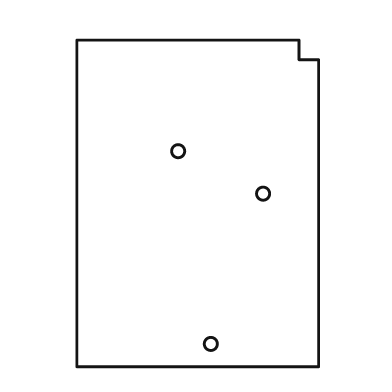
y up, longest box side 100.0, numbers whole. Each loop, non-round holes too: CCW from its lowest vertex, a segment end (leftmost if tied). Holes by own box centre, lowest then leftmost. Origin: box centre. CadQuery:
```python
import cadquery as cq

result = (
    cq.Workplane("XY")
    .moveTo(-37.0, -50.0)
    .lineTo(37.0, -50.0)
    .lineTo(37.0, 44.0)
    .lineTo(31.0, 44.0)
    .lineTo(31.0, 50.0)
    .lineTo(-37.0, 50.0)
    .close()
    .moveTo(4.0, -43.0)
    .circle(2.0)
    .moveTo(20.0, 3.0)
    .circle(2.0)
    .moveTo(-6.0, 16.0)
    .circle(2.0)
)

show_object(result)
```